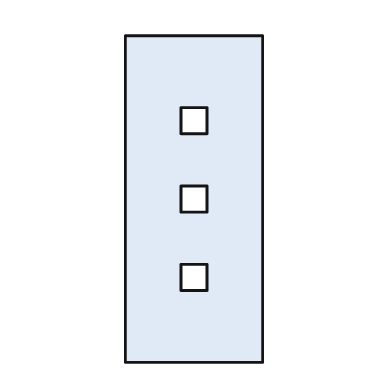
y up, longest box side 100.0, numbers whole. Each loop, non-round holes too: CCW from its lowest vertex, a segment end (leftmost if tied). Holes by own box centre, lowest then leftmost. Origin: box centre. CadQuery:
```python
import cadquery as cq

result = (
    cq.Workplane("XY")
    .moveTo(-21.0, -50.0)
    .lineTo(21.0, -50.0)
    .lineTo(21.0, 50.0)
    .lineTo(-21.0, 50.0)
    .close()
    .moveTo(-4.0, -28.0)
    .lineTo(4.0, -28.0)
    .lineTo(4.0, -20.0)
    .lineTo(-4.0, -20.0)
    .close()
    .moveTo(-4.0, -4.0)
    .lineTo(4.0, -4.0)
    .lineTo(4.0, 4.0)
    .lineTo(-4.0, 4.0)
    .close()
    .moveTo(-4.0, 20.0)
    .lineTo(4.0, 20.0)
    .lineTo(4.0, 28.0)
    .lineTo(-4.0, 28.0)
    .close()
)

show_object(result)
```